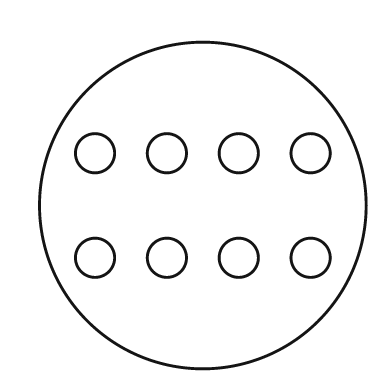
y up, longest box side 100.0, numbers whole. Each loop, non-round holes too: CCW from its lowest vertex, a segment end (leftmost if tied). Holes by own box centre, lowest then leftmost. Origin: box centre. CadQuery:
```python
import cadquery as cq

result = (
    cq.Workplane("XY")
    .moveTo(0.0, 0.0)
    .circle(50.0)
    .moveTo(-33.0, -16.0)
    .circle(6.0)
    .moveTo(-11.0, -16.0)
    .circle(6.0)
    .moveTo(11.0, -16.0)
    .circle(6.0)
    .moveTo(33.0, -16.0)
    .circle(6.0)
    .moveTo(-33.0, 16.0)
    .circle(6.0)
    .moveTo(-11.0, 16.0)
    .circle(6.0)
    .moveTo(11.0, 16.0)
    .circle(6.0)
    .moveTo(33.0, 16.0)
    .circle(6.0)
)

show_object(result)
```